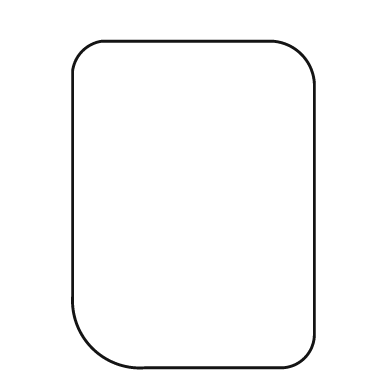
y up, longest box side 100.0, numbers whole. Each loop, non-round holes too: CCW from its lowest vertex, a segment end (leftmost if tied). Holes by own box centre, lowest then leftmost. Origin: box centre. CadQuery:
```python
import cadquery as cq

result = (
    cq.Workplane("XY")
    .moveTo(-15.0, -50.0)
    .lineTo(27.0, -50.0)
    .threePointArc((34.0, -47.0), (37.0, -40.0))
    .lineTo(37.0, 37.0)
    .threePointArc((33.0, 46.0), (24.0, 50.0))
    .lineTo(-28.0, 50.0)
    .threePointArc((-34.0, 47.0), (-37.0, 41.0))
    .lineTo(-37.0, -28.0)
    .threePointArc((-31.0, -44.0), (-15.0, -50.0))
    .close()
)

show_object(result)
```